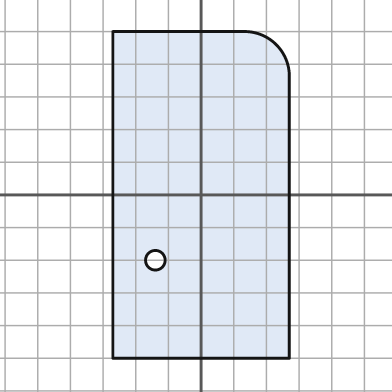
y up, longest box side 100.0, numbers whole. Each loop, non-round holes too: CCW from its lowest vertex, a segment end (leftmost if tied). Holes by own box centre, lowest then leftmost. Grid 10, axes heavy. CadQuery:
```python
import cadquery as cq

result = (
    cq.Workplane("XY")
    .moveTo(-27.0, -50.0)
    .lineTo(27.0, -50.0)
    .lineTo(27.0, 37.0)
    .threePointArc((23.0, 46.0), (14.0, 50.0))
    .lineTo(-27.0, 50.0)
    .close()
    .moveTo(-14.0, -20.0)
    .circle(3.0)
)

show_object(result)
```